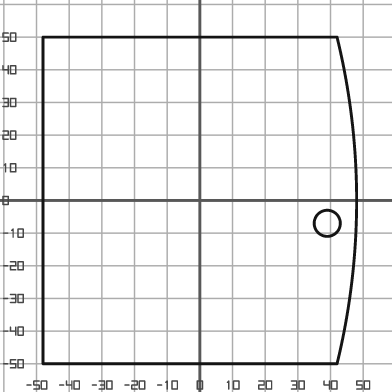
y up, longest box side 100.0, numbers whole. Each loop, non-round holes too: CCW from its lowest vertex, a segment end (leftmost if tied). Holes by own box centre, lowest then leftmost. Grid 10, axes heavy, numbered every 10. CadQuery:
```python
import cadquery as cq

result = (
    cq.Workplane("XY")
    .moveTo(-48.0, -50.0)
    .lineTo(42.0, -50.0)
    .threePointArc((48.0, 0.0), (42.0, 50.0))
    .lineTo(-48.0, 50.0)
    .close()
    .moveTo(39.0, -7.0)
    .circle(4.0)
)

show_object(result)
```